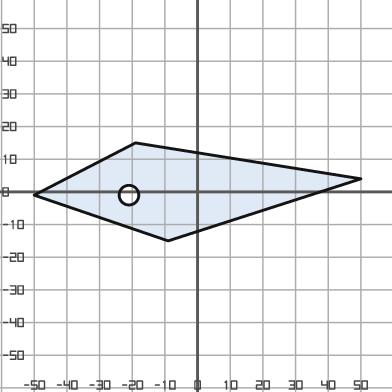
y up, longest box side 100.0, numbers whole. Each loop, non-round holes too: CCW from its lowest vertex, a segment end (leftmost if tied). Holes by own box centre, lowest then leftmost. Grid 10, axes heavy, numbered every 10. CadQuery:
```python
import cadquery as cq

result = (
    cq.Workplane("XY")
    .moveTo(-9.0, -15.0)
    .lineTo(50.0, 4.0)
    .lineTo(-19.0, 15.0)
    .lineTo(-50.0, -1.0)
    .close()
    .moveTo(-21.0, -1.0)
    .circle(3.0)
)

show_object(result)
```